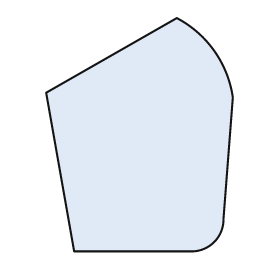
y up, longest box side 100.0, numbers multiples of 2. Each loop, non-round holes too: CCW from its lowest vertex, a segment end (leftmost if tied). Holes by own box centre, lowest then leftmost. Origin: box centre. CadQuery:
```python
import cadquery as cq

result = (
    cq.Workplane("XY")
    .moveTo(-28.0, -50.0)
    .lineTo(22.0, -50.0)
    .threePointArc((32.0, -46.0), (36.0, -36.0))
    .lineTo(40.0, 16.0)
    .threePointArc((32.0, 36.0), (16.0, 50.0))
    .lineTo(-40.0, 18.0)
    .close()
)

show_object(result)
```